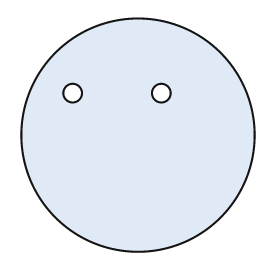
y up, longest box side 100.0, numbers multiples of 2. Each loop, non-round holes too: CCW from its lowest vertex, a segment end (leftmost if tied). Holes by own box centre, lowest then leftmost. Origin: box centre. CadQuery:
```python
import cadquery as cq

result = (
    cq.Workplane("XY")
    .moveTo(0.0, 0.0)
    .circle(50.0)
    .moveTo(-28.0, 18.0)
    .circle(4.0)
    .moveTo(10.0, 18.0)
    .circle(4.0)
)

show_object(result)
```